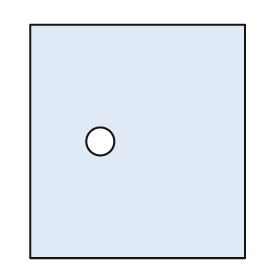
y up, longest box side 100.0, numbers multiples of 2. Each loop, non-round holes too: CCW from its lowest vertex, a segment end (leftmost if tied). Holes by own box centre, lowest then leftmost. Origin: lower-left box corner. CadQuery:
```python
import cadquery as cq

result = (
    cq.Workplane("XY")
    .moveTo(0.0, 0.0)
    .lineTo(92.0, 0.0)
    .lineTo(92.0, 100.0)
    .lineTo(0.0, 100.0)
    .close()
    .moveTo(30.0, 50.0)
    .circle(6.0)
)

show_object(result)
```